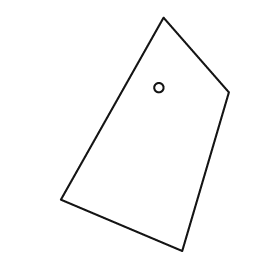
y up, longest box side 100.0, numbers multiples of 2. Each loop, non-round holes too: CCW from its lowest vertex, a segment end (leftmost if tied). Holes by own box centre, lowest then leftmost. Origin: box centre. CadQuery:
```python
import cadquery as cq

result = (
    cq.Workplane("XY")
    .moveTo(16.0, -50.0)
    .lineTo(36.0, 18.0)
    .lineTo(8.0, 50.0)
    .lineTo(-36.0, -28.0)
    .close()
    .moveTo(6.0, 20.0)
    .circle(2.0)
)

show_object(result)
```